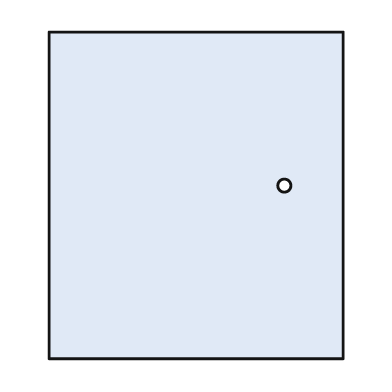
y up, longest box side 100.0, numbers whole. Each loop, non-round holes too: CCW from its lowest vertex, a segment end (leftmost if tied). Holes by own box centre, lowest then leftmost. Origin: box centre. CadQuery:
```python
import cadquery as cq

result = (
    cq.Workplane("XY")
    .moveTo(-45.0, -50.0)
    .lineTo(45.0, -50.0)
    .lineTo(45.0, 50.0)
    .lineTo(-45.0, 50.0)
    .close()
    .moveTo(27.0, 3.0)
    .circle(2.0)
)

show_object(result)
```